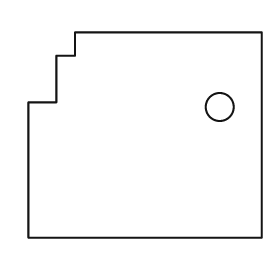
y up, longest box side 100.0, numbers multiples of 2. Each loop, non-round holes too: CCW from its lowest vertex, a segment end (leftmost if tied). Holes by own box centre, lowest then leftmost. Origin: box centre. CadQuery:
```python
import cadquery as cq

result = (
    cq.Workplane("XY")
    .moveTo(-50.0, -44.0)
    .lineTo(50.0, -44.0)
    .lineTo(50.0, 44.0)
    .lineTo(-30.0, 44.0)
    .lineTo(-30.0, 34.0)
    .lineTo(-38.0, 34.0)
    .lineTo(-38.0, 14.0)
    .lineTo(-50.0, 14.0)
    .close()
    .moveTo(32.0, 12.0)
    .circle(6.0)
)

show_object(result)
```